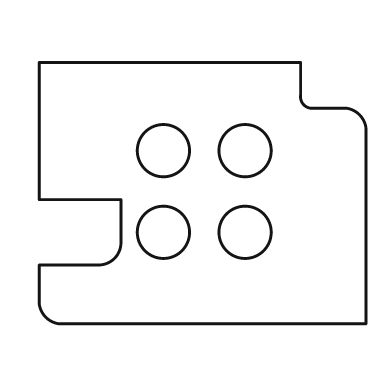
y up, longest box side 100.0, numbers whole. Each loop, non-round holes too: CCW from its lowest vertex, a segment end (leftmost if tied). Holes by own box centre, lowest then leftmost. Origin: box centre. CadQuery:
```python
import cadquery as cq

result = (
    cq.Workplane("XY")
    .moveTo(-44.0, -40.0)
    .lineTo(50.0, -40.0)
    .lineTo(50.0, 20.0)
    .threePointArc((48.0, 24.0), (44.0, 26.0))
    .lineTo(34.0, 26.0)
    .threePointArc((31.0, 27.0), (30.0, 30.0))
    .lineTo(30.0, 40.0)
    .lineTo(-50.0, 40.0)
    .lineTo(-50.0, -2.0)
    .lineTo(-25.0, -2.0)
    .lineTo(-25.0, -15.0)
    .threePointArc((-27.0, -20.0), (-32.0, -22.0))
    .lineTo(-50.0, -22.0)
    .lineTo(-50.0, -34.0)
    .threePointArc((-48.0, -38.0), (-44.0, -40.0))
    .close()
    .moveTo(-12.0, -12.0)
    .circle(8.0)
    .moveTo(13.0, -12.0)
    .circle(8.0)
    .moveTo(-12.0, 13.0)
    .circle(8.0)
    .moveTo(13.0, 13.0)
    .circle(8.0)
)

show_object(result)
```